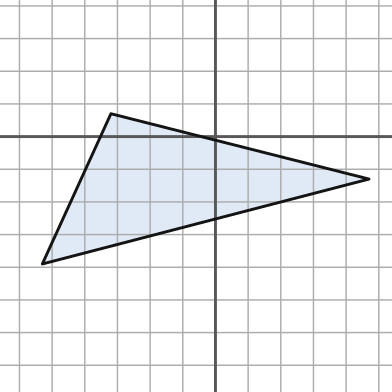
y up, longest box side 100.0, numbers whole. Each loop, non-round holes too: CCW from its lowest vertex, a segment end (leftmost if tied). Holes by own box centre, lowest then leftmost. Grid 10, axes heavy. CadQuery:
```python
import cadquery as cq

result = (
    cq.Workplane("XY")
    .moveTo(-53.0, -39.0)
    .lineTo(47.0, -13.0)
    .lineTo(-32.0, 7.0)
    .close()
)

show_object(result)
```